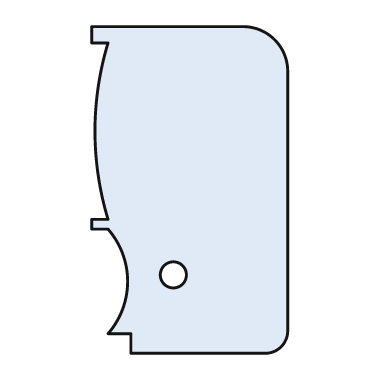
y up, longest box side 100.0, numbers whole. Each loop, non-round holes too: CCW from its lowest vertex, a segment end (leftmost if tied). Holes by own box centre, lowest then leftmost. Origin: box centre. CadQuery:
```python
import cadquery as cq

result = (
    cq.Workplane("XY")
    .moveTo(-18.0, -50.0)
    .lineTo(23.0, -50.0)
    .threePointArc((28.0, -48.0), (30.0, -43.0))
    .lineTo(30.0, 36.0)
    .threePointArc((26.0, 46.0), (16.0, 50.0))
    .lineTo(-30.0, 50.0)
    .lineTo(-30.0, 45.0)
    .lineTo(-25.0, 45.0)
    .threePointArc((-29.0, 18.0), (-25.0, -9.0))
    .lineTo(-30.0, -9.0)
    .lineTo(-30.0, -12.0)
    .lineTo(-25.0, -12.0)
    .threePointArc((-19.0, -28.0), (-25.0, -44.0))
    .lineTo(-18.0, -44.0)
    .close()
    .moveTo(-5.0, -26.0)
    .circle(4.0)
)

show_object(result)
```